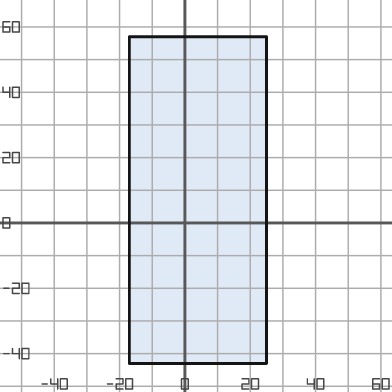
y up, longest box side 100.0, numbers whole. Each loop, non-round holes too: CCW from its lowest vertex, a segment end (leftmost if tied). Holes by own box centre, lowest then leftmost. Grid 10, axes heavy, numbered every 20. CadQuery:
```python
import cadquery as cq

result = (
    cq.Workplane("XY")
    .moveTo(-17.0, -43.0)
    .lineTo(25.0, -43.0)
    .lineTo(25.0, 57.0)
    .lineTo(-17.0, 57.0)
    .close()
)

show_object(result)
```